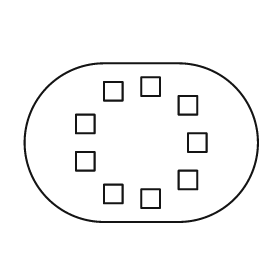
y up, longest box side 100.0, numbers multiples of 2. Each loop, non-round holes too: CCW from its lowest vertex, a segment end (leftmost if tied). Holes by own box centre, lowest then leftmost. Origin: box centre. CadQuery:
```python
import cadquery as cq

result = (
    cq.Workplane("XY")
    .moveTo(-16.0, -34.0)
    .lineTo(16.0, -34.0)
    .threePointArc((50.0, 0.0), (16.0, 34.0))
    .lineTo(-16.0, 34.0)
    .threePointArc((-50.0, 0.0), (-16.0, -34.0))
    .close()
    .moveTo(0.0, -28.0)
    .lineTo(8.0, -28.0)
    .lineTo(8.0, -20.0)
    .lineTo(0.0, -20.0)
    .close()
    .moveTo(-16.0, -26.0)
    .lineTo(-8.0, -26.0)
    .lineTo(-8.0, -18.0)
    .lineTo(-16.0, -18.0)
    .close()
    .moveTo(16.0, -20.0)
    .lineTo(24.0, -20.0)
    .lineTo(24.0, -12.0)
    .lineTo(16.0, -12.0)
    .close()
    .moveTo(-28.0, -12.0)
    .lineTo(-20.0, -12.0)
    .lineTo(-20.0, -4.0)
    .lineTo(-28.0, -4.0)
    .close()
    .moveTo(20.0, -4.0)
    .lineTo(28.0, -4.0)
    .lineTo(28.0, 4.0)
    .lineTo(20.0, 4.0)
    .close()
    .moveTo(-28.0, 4.0)
    .lineTo(-20.0, 4.0)
    .lineTo(-20.0, 12.0)
    .lineTo(-28.0, 12.0)
    .close()
    .moveTo(16.0, 12.0)
    .lineTo(24.0, 12.0)
    .lineTo(24.0, 20.0)
    .lineTo(16.0, 20.0)
    .close()
    .moveTo(-16.0, 18.0)
    .lineTo(-8.0, 18.0)
    .lineTo(-8.0, 26.0)
    .lineTo(-16.0, 26.0)
    .close()
    .moveTo(0.0, 20.0)
    .lineTo(8.0, 20.0)
    .lineTo(8.0, 28.0)
    .lineTo(0.0, 28.0)
    .close()
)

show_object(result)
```